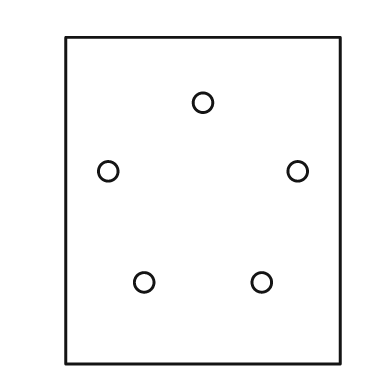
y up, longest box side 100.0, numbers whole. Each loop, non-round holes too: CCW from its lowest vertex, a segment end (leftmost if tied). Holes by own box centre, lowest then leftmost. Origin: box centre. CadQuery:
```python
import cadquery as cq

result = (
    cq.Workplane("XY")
    .moveTo(-42.0, -50.0)
    .lineTo(42.0, -50.0)
    .lineTo(42.0, 50.0)
    .lineTo(-42.0, 50.0)
    .close()
    .moveTo(-18.0, -25.0)
    .circle(3.0)
    .moveTo(18.0, -25.0)
    .circle(3.0)
    .moveTo(-29.0, 9.0)
    .circle(3.0)
    .moveTo(29.0, 9.0)
    .circle(3.0)
    .moveTo(0.0, 30.0)
    .circle(3.0)
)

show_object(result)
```